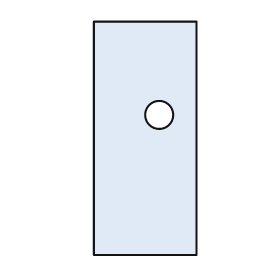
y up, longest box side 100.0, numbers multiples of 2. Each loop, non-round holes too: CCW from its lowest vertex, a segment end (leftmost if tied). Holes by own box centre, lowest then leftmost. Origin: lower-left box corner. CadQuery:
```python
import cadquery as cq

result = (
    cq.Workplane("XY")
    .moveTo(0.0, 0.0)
    .lineTo(44.0, 0.0)
    .lineTo(44.0, 100.0)
    .lineTo(0.0, 100.0)
    .close()
    .moveTo(28.0, 60.0)
    .circle(6.0)
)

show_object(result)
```